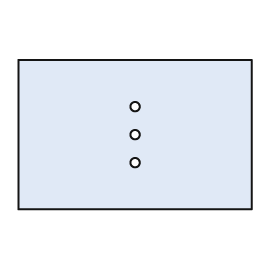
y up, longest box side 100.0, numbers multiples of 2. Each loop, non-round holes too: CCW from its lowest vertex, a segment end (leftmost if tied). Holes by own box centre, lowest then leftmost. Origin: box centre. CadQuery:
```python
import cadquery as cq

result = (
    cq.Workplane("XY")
    .moveTo(-50.0, -32.0)
    .lineTo(50.0, -32.0)
    .lineTo(50.0, 32.0)
    .lineTo(-50.0, 32.0)
    .close()
    .moveTo(0.0, -12.0)
    .circle(2.0)
    .moveTo(0.0, 0.0)
    .circle(2.0)
    .moveTo(0.0, 12.0)
    .circle(2.0)
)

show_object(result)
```